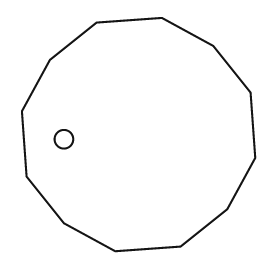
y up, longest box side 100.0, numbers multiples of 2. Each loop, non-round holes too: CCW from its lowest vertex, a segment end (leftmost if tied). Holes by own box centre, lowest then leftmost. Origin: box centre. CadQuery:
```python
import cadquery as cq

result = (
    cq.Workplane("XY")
    .moveTo(-10.0, -50.0)
    .lineTo(18.0, -48.0)
    .lineTo(38.0, -32.0)
    .lineTo(50.0, -10.0)
    .lineTo(48.0, 18.0)
    .lineTo(32.0, 38.0)
    .lineTo(10.0, 50.0)
    .lineTo(-18.0, 48.0)
    .lineTo(-38.0, 32.0)
    .lineTo(-50.0, 10.0)
    .lineTo(-48.0, -18.0)
    .lineTo(-32.0, -38.0)
    .close()
    .moveTo(-32.0, -2.0)
    .circle(4.0)
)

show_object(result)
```